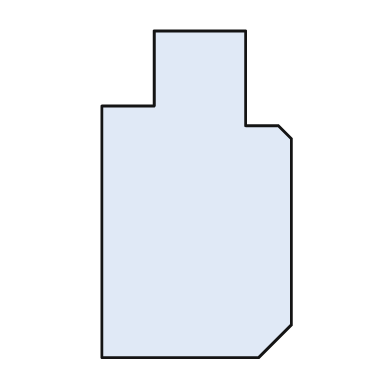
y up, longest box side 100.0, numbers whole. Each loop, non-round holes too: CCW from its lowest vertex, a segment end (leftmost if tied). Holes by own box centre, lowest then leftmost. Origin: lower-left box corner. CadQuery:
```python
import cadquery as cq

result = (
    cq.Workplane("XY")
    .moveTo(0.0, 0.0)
    .lineTo(48.0, 0.0)
    .lineTo(58.0, 10.0)
    .lineTo(58.0, 67.0)
    .lineTo(54.0, 71.0)
    .lineTo(44.0, 71.0)
    .lineTo(44.0, 100.0)
    .lineTo(16.0, 100.0)
    .lineTo(16.0, 77.0)
    .lineTo(0.0, 77.0)
    .close()
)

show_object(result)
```